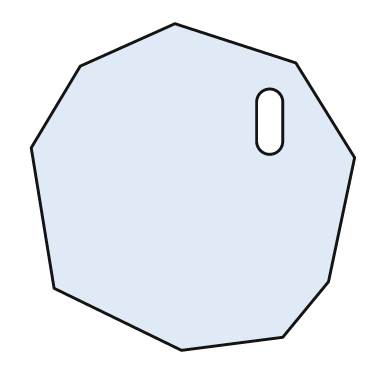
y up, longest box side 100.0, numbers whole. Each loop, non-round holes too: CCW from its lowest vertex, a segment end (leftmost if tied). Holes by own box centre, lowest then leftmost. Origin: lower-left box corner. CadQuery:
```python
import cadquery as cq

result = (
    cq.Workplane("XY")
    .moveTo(46.0, 0.0)
    .lineTo(77.0, 4.0)
    .lineTo(91.0, 21.0)
    .lineTo(99.0, 59.0)
    .lineTo(81.0, 88.0)
    .lineTo(44.0, 100.0)
    .lineTo(15.0, 87.0)
    .lineTo(0.0, 62.0)
    .lineTo(7.0, 19.0)
    .close()
    .moveTo(69.0, 64.0)
    .threePointArc((73.0, 60.0), (77.0, 64.0))
    .lineTo(77.0, 76.0)
    .threePointArc((73.0, 80.0), (69.0, 76.0))
    .close()
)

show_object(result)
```